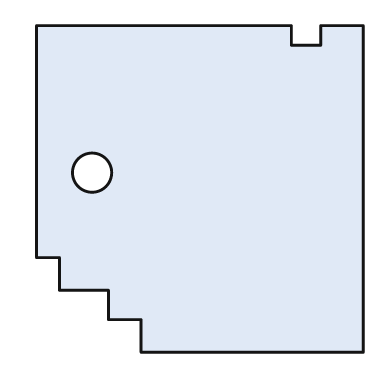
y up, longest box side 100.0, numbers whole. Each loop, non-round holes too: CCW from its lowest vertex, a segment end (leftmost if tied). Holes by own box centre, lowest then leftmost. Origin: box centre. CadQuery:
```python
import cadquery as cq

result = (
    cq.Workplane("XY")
    .moveTo(-18.0, -50.0)
    .lineTo(50.0, -50.0)
    .lineTo(50.0, 50.0)
    .lineTo(37.0, 50.0)
    .lineTo(37.0, 44.0)
    .lineTo(28.0, 44.0)
    .lineTo(28.0, 50.0)
    .lineTo(-50.0, 50.0)
    .lineTo(-50.0, -21.0)
    .lineTo(-43.0, -21.0)
    .lineTo(-43.0, -31.0)
    .lineTo(-28.0, -31.0)
    .lineTo(-28.0, -40.0)
    .lineTo(-18.0, -40.0)
    .close()
    .moveTo(-33.0, 5.0)
    .circle(6.0)
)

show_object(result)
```